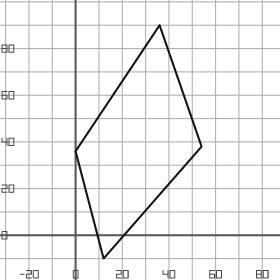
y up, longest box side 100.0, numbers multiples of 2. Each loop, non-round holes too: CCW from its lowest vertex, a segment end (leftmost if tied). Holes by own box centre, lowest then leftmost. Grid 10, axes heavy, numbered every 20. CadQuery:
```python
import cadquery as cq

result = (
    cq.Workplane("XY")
    .moveTo(12.0, -10.0)
    .lineTo(54.0, 38.0)
    .lineTo(36.0, 90.0)
    .lineTo(0.0, 36.0)
    .close()
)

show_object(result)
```